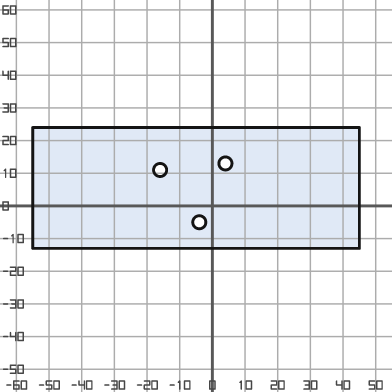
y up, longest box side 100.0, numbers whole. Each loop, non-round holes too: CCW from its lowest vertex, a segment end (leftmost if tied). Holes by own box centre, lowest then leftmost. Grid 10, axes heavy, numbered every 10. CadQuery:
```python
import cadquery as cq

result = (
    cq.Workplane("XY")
    .moveTo(-55.0, -13.0)
    .lineTo(45.0, -13.0)
    .lineTo(45.0, 24.0)
    .lineTo(-55.0, 24.0)
    .close()
    .moveTo(-4.0, -5.0)
    .circle(2.0)
    .moveTo(-16.0, 11.0)
    .circle(2.0)
    .moveTo(4.0, 13.0)
    .circle(2.0)
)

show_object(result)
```